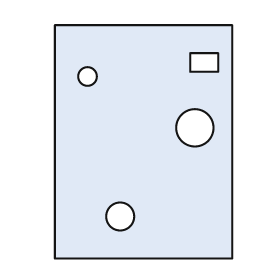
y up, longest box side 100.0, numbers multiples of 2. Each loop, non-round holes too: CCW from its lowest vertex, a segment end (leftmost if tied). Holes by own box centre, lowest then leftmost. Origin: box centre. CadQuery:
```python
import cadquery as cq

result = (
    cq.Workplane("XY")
    .moveTo(-38.0, -50.0)
    .lineTo(38.0, -50.0)
    .lineTo(38.0, 50.0)
    .lineTo(-38.0, 50.0)
    .close()
    .moveTo(-10.0, -32.0)
    .circle(6.0)
    .moveTo(22.0, 6.0)
    .circle(8.0)
    .moveTo(-24.0, 28.0)
    .circle(4.0)
    .moveTo(20.0, 30.0)
    .lineTo(32.0, 30.0)
    .lineTo(32.0, 38.0)
    .lineTo(20.0, 38.0)
    .close()
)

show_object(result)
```